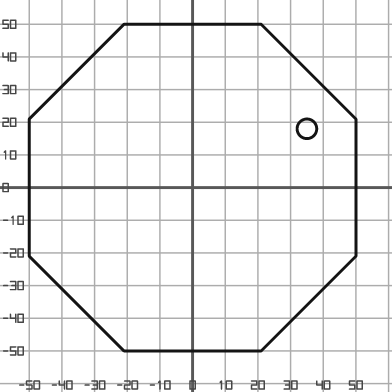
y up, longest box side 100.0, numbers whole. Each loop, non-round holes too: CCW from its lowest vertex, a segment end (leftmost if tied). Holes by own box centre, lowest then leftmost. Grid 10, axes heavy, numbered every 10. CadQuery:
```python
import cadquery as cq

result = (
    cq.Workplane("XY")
    .moveTo(-21.0, -50.0)
    .lineTo(21.0, -50.0)
    .lineTo(50.0, -21.0)
    .lineTo(50.0, 21.0)
    .lineTo(21.0, 50.0)
    .lineTo(-21.0, 50.0)
    .lineTo(-50.0, 21.0)
    .lineTo(-50.0, -21.0)
    .close()
    .moveTo(35.0, 18.0)
    .circle(3.0)
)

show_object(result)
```